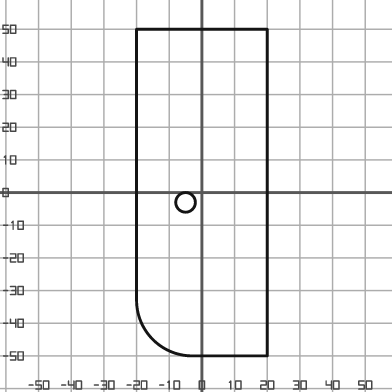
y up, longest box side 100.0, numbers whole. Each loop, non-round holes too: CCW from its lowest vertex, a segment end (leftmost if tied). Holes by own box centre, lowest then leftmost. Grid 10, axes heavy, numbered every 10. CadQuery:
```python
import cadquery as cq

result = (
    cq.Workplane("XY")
    .moveTo(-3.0, -50.0)
    .lineTo(20.0, -50.0)
    .lineTo(20.0, 50.0)
    .lineTo(-20.0, 50.0)
    .lineTo(-20.0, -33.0)
    .threePointArc((-15.0, -45.0), (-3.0, -50.0))
    .close()
    .moveTo(-5.0, -3.0)
    .circle(3.0)
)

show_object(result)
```